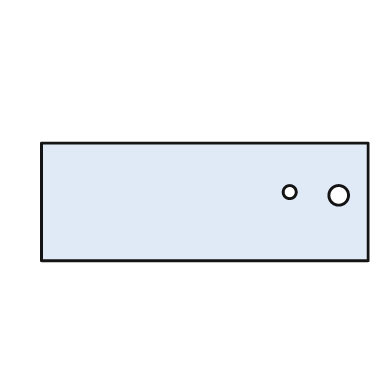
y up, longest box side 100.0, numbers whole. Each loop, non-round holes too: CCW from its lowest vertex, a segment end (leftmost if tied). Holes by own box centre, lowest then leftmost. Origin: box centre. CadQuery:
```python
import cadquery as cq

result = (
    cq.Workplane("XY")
    .moveTo(-50.0, -18.0)
    .lineTo(50.0, -18.0)
    .lineTo(50.0, 18.0)
    .lineTo(-50.0, 18.0)
    .close()
    .moveTo(41.0, 2.0)
    .circle(3.0)
    .moveTo(26.0, 3.0)
    .circle(2.0)
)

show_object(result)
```